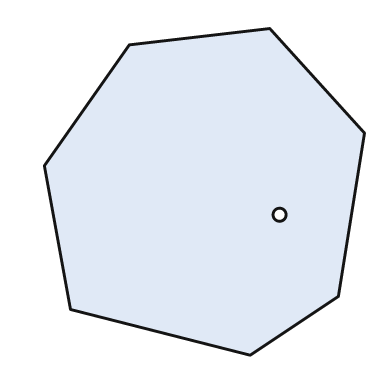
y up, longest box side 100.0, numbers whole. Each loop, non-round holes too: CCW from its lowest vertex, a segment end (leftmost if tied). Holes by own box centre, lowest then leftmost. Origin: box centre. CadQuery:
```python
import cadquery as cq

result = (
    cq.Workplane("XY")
    .moveTo(14.0, -50.0)
    .lineTo(41.0, -32.0)
    .lineTo(49.0, 18.0)
    .lineTo(20.0, 50.0)
    .lineTo(-23.0, 45.0)
    .lineTo(-49.0, 8.0)
    .lineTo(-41.0, -36.0)
    .close()
    .moveTo(23.0, -7.0)
    .circle(2.0)
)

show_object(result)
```